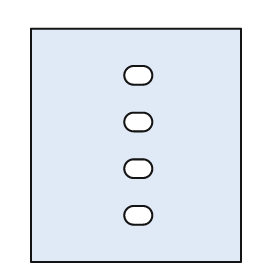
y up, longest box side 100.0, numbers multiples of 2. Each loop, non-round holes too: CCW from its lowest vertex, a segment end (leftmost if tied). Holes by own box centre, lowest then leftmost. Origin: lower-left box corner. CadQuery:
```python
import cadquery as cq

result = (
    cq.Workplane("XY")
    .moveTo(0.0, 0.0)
    .lineTo(90.0, 0.0)
    .lineTo(90.0, 100.0)
    .lineTo(0.0, 100.0)
    .close()
    .moveTo(44.0, 16.0)
    .lineTo(48.0, 16.0)
    .threePointArc((52.0, 20.0), (48.0, 24.0))
    .lineTo(44.0, 24.0)
    .threePointArc((40.0, 20.0), (44.0, 16.0))
    .close()
    .moveTo(44.0, 36.0)
    .lineTo(48.0, 36.0)
    .threePointArc((52.0, 40.0), (48.0, 44.0))
    .lineTo(44.0, 44.0)
    .threePointArc((40.0, 40.0), (44.0, 36.0))
    .close()
    .moveTo(44.0, 56.0)
    .lineTo(48.0, 56.0)
    .threePointArc((52.0, 60.0), (48.0, 64.0))
    .lineTo(44.0, 64.0)
    .threePointArc((40.0, 60.0), (44.0, 56.0))
    .close()
    .moveTo(44.0, 76.0)
    .lineTo(48.0, 76.0)
    .threePointArc((52.0, 80.0), (48.0, 84.0))
    .lineTo(44.0, 84.0)
    .threePointArc((40.0, 80.0), (44.0, 76.0))
    .close()
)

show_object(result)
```